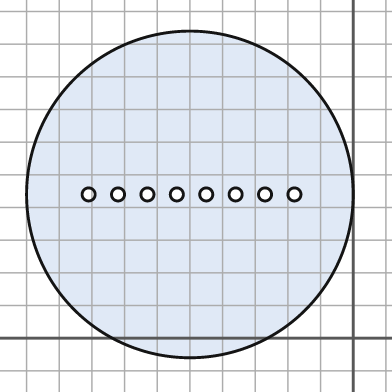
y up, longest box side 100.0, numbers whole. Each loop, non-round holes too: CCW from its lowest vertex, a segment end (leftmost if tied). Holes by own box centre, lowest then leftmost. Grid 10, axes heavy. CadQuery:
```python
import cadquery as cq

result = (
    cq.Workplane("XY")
    .moveTo(-50.0, 44.0)
    .circle(50.0)
    .moveTo(-81.0, 44.0)
    .circle(2.0)
    .moveTo(-72.0, 44.0)
    .circle(2.0)
    .moveTo(-63.0, 44.0)
    .circle(2.0)
    .moveTo(-54.0, 44.0)
    .circle(2.0)
    .moveTo(-45.0, 44.0)
    .circle(2.0)
    .moveTo(-36.0, 44.0)
    .circle(2.0)
    .moveTo(-27.0, 44.0)
    .circle(2.0)
    .moveTo(-18.0, 44.0)
    .circle(2.0)
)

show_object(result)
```